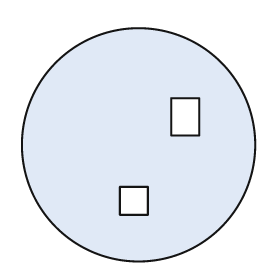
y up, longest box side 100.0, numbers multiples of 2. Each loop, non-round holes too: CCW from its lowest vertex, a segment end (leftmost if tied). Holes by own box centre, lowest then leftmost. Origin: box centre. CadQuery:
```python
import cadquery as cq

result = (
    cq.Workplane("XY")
    .moveTo(0.0, 0.0)
    .circle(50.0)
    .moveTo(-8.0, -30.0)
    .lineTo(4.0, -30.0)
    .lineTo(4.0, -18.0)
    .lineTo(-8.0, -18.0)
    .close()
    .moveTo(14.0, 4.0)
    .lineTo(26.0, 4.0)
    .lineTo(26.0, 20.0)
    .lineTo(14.0, 20.0)
    .close()
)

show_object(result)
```